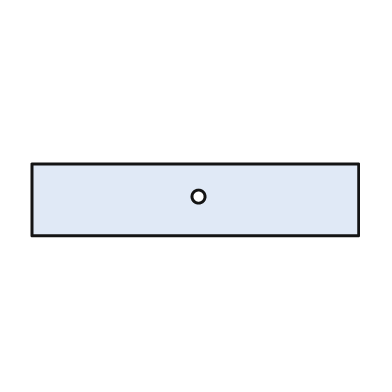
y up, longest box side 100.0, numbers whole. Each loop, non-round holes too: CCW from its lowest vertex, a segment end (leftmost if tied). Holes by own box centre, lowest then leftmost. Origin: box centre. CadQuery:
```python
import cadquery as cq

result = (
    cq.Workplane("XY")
    .moveTo(-50.0, -11.0)
    .lineTo(50.0, -11.0)
    .lineTo(50.0, 11.0)
    .lineTo(-50.0, 11.0)
    .close()
    .moveTo(1.0, 1.0)
    .circle(2.0)
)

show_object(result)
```